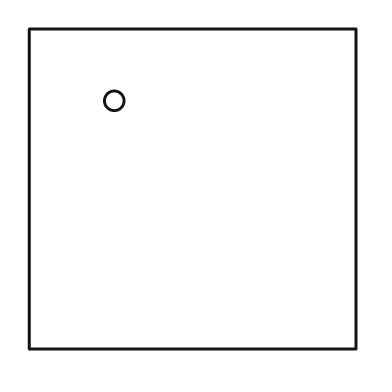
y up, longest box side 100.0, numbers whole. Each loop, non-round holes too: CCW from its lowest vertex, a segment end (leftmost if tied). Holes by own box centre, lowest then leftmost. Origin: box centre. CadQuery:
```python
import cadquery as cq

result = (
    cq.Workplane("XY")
    .moveTo(-50.0, -49.0)
    .lineTo(50.0, -49.0)
    .lineTo(50.0, 49.0)
    .lineTo(-50.0, 49.0)
    .close()
    .moveTo(-24.0, 27.0)
    .circle(3.0)
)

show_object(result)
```